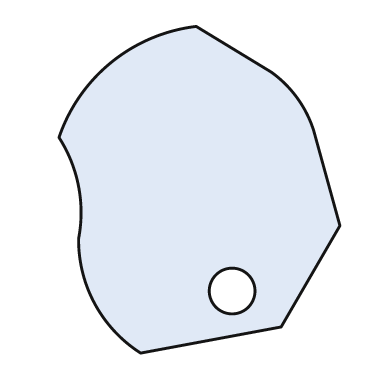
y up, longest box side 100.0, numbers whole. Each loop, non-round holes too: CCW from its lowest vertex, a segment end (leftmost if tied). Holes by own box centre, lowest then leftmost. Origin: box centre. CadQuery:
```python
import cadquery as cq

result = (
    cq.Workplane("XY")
    .moveTo(-18.0, -50.0)
    .lineTo(25.0, -42.0)
    .lineTo(43.0, -11.0)
    .lineTo(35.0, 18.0)
    .threePointArc((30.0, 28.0), (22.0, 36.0))
    .lineTo(-1.0, 50.0)
    .threePointArc((-27.0, 39.0), (-43.0, 16.0))
    .threePointArc((-37.0, 1.0), (-37.0, -15.0))
    .threePointArc((-32.0, -35.0), (-18.0, -50.0))
    .close()
    .moveTo(10.0, -31.0)
    .circle(7.0)
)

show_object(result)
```